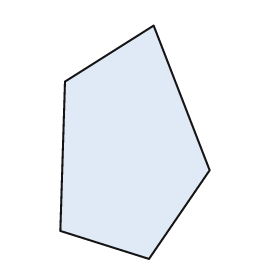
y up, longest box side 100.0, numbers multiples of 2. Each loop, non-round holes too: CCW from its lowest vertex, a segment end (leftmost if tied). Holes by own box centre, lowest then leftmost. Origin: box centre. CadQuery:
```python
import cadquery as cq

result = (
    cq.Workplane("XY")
    .moveTo(6.0, -50.0)
    .lineTo(32.0, -12.0)
    .lineTo(8.0, 50.0)
    .lineTo(-30.0, 26.0)
    .lineTo(-32.0, -38.0)
    .close()
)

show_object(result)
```